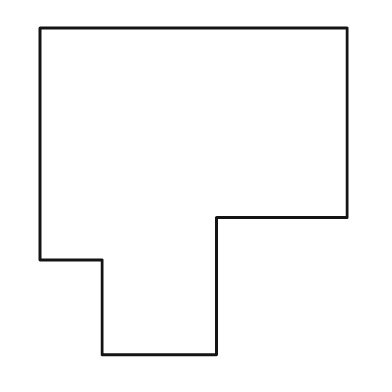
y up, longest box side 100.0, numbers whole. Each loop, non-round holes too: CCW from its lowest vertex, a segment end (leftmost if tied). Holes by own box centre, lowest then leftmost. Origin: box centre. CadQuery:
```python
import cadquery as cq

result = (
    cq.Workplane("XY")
    .moveTo(-28.0, -50.0)
    .lineTo(7.0, -50.0)
    .lineTo(7.0, -8.0)
    .lineTo(47.0, -8.0)
    .lineTo(47.0, 50.0)
    .lineTo(-47.0, 50.0)
    .lineTo(-47.0, -21.0)
    .lineTo(-28.0, -21.0)
    .close()
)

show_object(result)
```